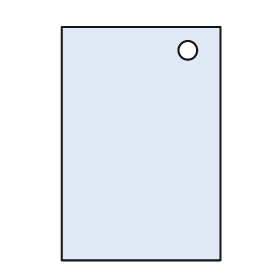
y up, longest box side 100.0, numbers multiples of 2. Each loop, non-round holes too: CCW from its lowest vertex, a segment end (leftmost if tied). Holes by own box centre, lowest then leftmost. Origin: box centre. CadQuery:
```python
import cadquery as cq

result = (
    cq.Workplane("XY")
    .moveTo(-34.0, -50.0)
    .lineTo(34.0, -50.0)
    .lineTo(34.0, 50.0)
    .lineTo(-34.0, 50.0)
    .close()
    .moveTo(20.0, 40.0)
    .circle(4.0)
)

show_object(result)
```